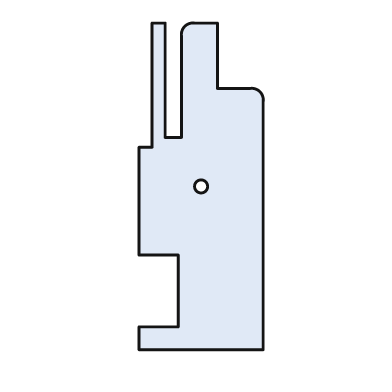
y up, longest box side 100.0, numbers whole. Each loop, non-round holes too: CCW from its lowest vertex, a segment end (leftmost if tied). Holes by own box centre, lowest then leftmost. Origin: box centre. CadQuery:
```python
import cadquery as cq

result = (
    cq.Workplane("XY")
    .moveTo(-19.0, -50.0)
    .lineTo(19.0, -50.0)
    .lineTo(19.0, 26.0)
    .threePointArc((18.0, 29.0), (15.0, 30.0))
    .lineTo(5.0, 30.0)
    .lineTo(5.0, 50.0)
    .lineTo(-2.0, 50.0)
    .threePointArc((-5.0, 49.0), (-6.0, 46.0))
    .lineTo(-6.0, 15.0)
    .lineTo(-11.0, 15.0)
    .lineTo(-11.0, 50.0)
    .lineTo(-15.0, 50.0)
    .lineTo(-15.0, 12.0)
    .lineTo(-19.0, 12.0)
    .lineTo(-19.0, -21.0)
    .lineTo(-7.0, -21.0)
    .lineTo(-7.0, -43.0)
    .lineTo(-19.0, -43.0)
    .close()
    .moveTo(0.0, 0.0)
    .circle(2.0)
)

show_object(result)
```